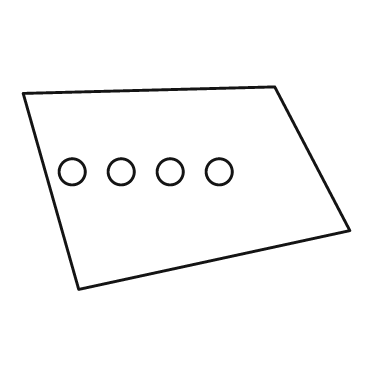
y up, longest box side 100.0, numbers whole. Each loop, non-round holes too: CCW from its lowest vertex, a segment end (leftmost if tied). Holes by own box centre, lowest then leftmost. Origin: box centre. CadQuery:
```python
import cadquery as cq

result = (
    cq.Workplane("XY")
    .moveTo(-33.0, -31.0)
    .lineTo(50.0, -13.0)
    .lineTo(27.0, 31.0)
    .lineTo(-50.0, 29.0)
    .close()
    .moveTo(-35.0, 5.0)
    .circle(4.0)
    .moveTo(-20.0, 5.0)
    .circle(4.0)
    .moveTo(-5.0, 5.0)
    .circle(4.0)
    .moveTo(10.0, 5.0)
    .circle(4.0)
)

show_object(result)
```